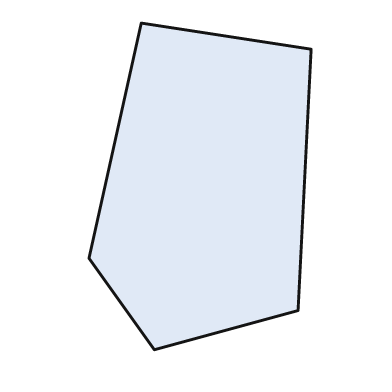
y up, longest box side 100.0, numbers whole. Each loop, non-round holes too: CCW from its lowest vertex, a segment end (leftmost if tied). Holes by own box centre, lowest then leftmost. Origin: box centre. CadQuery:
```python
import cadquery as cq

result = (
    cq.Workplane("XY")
    .moveTo(-14.0, -50.0)
    .lineTo(30.0, -38.0)
    .lineTo(34.0, 42.0)
    .lineTo(-18.0, 50.0)
    .lineTo(-34.0, -22.0)
    .close()
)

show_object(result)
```